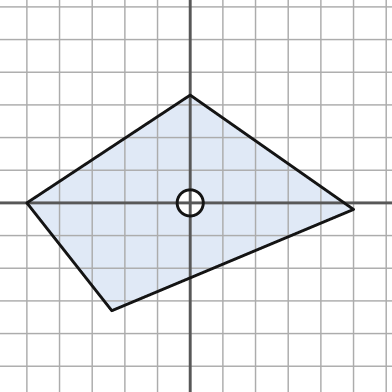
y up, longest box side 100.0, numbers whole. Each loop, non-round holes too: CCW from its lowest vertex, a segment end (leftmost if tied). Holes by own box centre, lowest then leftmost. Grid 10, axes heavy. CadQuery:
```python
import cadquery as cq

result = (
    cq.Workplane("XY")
    .moveTo(-24.0, -33.0)
    .lineTo(50.0, -2.0)
    .lineTo(0.0, 33.0)
    .lineTo(-50.0, 0.0)
    .close()
    .moveTo(0.0, 0.0)
    .circle(4.0)
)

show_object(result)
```